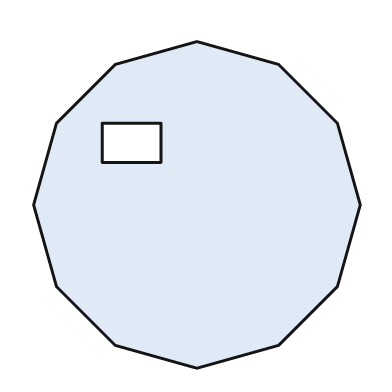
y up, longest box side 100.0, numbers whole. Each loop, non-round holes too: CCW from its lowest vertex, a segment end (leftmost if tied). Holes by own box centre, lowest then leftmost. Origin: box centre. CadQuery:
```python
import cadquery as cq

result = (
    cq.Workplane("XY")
    .moveTo(0.0, -50.0)
    .lineTo(25.0, -43.0)
    .lineTo(43.0, -25.0)
    .lineTo(50.0, 0.0)
    .lineTo(43.0, 25.0)
    .lineTo(25.0, 43.0)
    .lineTo(0.0, 50.0)
    .lineTo(-25.0, 43.0)
    .lineTo(-43.0, 25.0)
    .lineTo(-50.0, 0.0)
    .lineTo(-43.0, -25.0)
    .lineTo(-25.0, -43.0)
    .close()
    .moveTo(-29.0, 13.0)
    .lineTo(-11.0, 13.0)
    .lineTo(-11.0, 25.0)
    .lineTo(-29.0, 25.0)
    .close()
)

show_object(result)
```